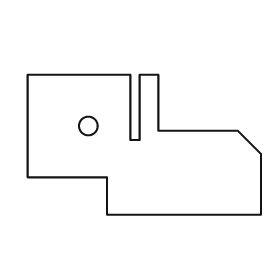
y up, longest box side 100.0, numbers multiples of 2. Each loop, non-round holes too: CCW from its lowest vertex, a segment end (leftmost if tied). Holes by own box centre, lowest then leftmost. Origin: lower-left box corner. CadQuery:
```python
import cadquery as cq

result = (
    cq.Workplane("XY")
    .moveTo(34.0, 0.0)
    .lineTo(100.0, 0.0)
    .lineTo(100.0, 26.0)
    .lineTo(90.0, 36.0)
    .lineTo(56.0, 36.0)
    .lineTo(56.0, 60.0)
    .lineTo(48.0, 60.0)
    .lineTo(48.0, 32.0)
    .lineTo(44.0, 32.0)
    .lineTo(44.0, 60.0)
    .lineTo(0.0, 60.0)
    .lineTo(0.0, 16.0)
    .lineTo(34.0, 16.0)
    .close()
    .moveTo(26.0, 38.0)
    .circle(4.0)
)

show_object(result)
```